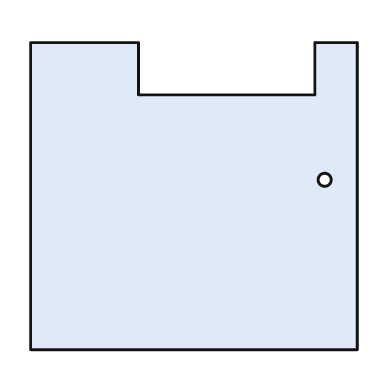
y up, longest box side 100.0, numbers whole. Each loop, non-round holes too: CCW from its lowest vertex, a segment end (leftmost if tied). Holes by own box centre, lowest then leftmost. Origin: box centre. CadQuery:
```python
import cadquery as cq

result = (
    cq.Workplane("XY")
    .moveTo(-50.0, -47.0)
    .lineTo(50.0, -47.0)
    .lineTo(50.0, 47.0)
    .lineTo(37.0, 47.0)
    .lineTo(37.0, 31.0)
    .lineTo(-17.0, 31.0)
    .lineTo(-17.0, 47.0)
    .lineTo(-50.0, 47.0)
    .close()
    .moveTo(40.0, 5.0)
    .circle(2.0)
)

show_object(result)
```